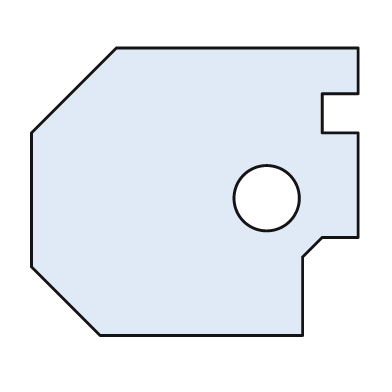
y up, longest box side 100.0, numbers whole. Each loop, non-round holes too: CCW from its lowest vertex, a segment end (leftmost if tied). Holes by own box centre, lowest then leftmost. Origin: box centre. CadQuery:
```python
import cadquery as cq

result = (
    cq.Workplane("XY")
    .moveTo(-29.0, -44.0)
    .lineTo(33.0, -44.0)
    .lineTo(33.0, -20.0)
    .lineTo(39.0, -14.0)
    .lineTo(50.0, -14.0)
    .lineTo(50.0, 18.0)
    .lineTo(39.0, 18.0)
    .lineTo(39.0, 30.0)
    .lineTo(50.0, 30.0)
    .lineTo(50.0, 44.0)
    .lineTo(-24.0, 44.0)
    .lineTo(-50.0, 18.0)
    .lineTo(-50.0, -23.0)
    .close()
    .moveTo(22.0, -2.0)
    .circle(10.0)
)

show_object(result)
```